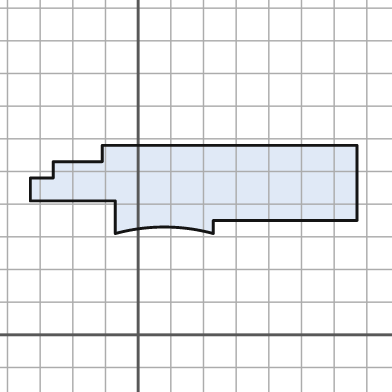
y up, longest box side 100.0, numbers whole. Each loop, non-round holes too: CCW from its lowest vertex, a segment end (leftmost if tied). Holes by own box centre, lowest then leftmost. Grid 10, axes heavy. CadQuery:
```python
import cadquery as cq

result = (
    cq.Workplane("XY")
    .moveTo(-7.0, 31.0)
    .threePointArc((8.0, 33.0), (23.0, 31.0))
    .lineTo(23.0, 35.0)
    .lineTo(67.0, 35.0)
    .lineTo(67.0, 58.0)
    .lineTo(-11.0, 58.0)
    .lineTo(-11.0, 53.0)
    .lineTo(-26.0, 53.0)
    .lineTo(-26.0, 48.0)
    .lineTo(-33.0, 48.0)
    .lineTo(-33.0, 41.0)
    .lineTo(-7.0, 41.0)
    .close()
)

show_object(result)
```